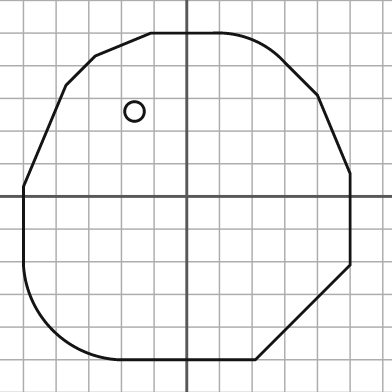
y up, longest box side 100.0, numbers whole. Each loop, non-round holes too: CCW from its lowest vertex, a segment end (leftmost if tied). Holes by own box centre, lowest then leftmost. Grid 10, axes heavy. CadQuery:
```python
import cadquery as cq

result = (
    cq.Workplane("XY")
    .moveTo(-21.0, -50.0)
    .lineTo(21.0, -50.0)
    .lineTo(50.0, -21.0)
    .lineTo(50.0, 7.0)
    .lineTo(40.0, 31.0)
    .lineTo(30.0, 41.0)
    .threePointArc((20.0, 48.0), (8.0, 50.0))
    .lineTo(-11.0, 50.0)
    .lineTo(-28.0, 43.0)
    .lineTo(-37.0, 34.0)
    .lineTo(-50.0, 3.0)
    .lineTo(-50.0, -21.0)
    .threePointArc((-41.0, -41.0), (-21.0, -50.0))
    .close()
    .moveTo(-16.0, 26.0)
    .circle(3.0)
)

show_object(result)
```